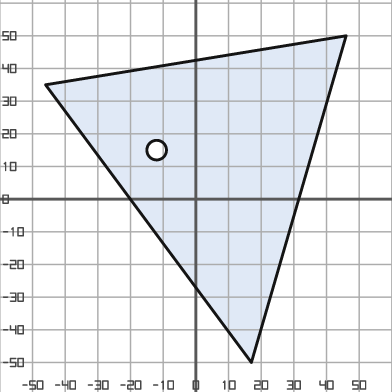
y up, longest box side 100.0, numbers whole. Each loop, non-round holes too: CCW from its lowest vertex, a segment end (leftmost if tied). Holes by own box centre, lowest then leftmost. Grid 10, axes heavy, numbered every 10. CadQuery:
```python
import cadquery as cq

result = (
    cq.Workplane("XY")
    .moveTo(17.0, -50.0)
    .lineTo(46.0, 50.0)
    .lineTo(-46.0, 35.0)
    .close()
    .moveTo(-12.0, 15.0)
    .circle(3.0)
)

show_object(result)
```